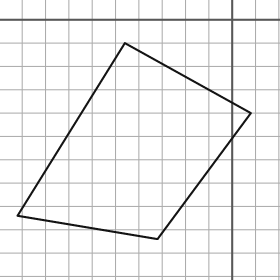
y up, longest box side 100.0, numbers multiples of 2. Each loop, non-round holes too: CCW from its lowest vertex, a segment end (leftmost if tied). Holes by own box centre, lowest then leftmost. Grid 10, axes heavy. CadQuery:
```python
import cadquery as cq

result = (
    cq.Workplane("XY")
    .moveTo(-32.0, -94.0)
    .lineTo(8.0, -40.0)
    .lineTo(-46.0, -10.0)
    .lineTo(-92.0, -84.0)
    .close()
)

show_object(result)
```